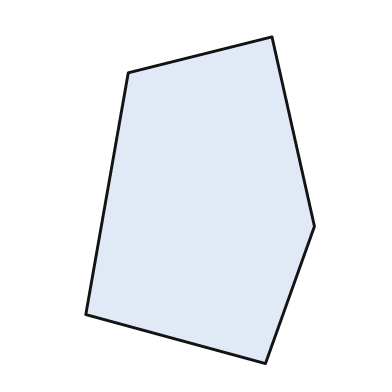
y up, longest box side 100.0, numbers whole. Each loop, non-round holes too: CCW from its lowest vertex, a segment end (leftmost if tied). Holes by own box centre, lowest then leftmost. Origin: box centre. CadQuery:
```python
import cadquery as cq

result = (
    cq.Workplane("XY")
    .moveTo(20.0, -50.0)
    .lineTo(35.0, -8.0)
    .lineTo(22.0, 50.0)
    .lineTo(-22.0, 39.0)
    .lineTo(-35.0, -35.0)
    .close()
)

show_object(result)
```